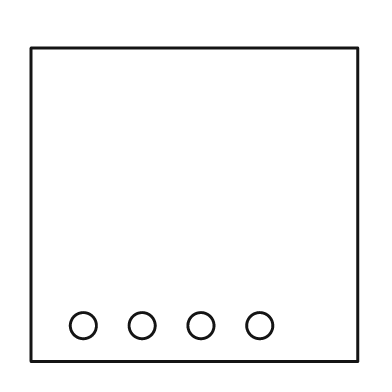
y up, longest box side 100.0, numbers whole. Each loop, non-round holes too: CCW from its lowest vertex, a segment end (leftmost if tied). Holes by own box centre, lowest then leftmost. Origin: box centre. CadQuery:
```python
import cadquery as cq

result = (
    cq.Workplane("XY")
    .moveTo(-50.0, -48.0)
    .lineTo(50.0, -48.0)
    .lineTo(50.0, 48.0)
    .lineTo(-50.0, 48.0)
    .close()
    .moveTo(-34.0, -37.0)
    .circle(4.0)
    .moveTo(-16.0, -37.0)
    .circle(4.0)
    .moveTo(2.0, -37.0)
    .circle(4.0)
    .moveTo(20.0, -37.0)
    .circle(4.0)
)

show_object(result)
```